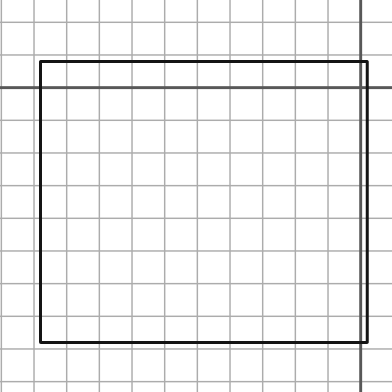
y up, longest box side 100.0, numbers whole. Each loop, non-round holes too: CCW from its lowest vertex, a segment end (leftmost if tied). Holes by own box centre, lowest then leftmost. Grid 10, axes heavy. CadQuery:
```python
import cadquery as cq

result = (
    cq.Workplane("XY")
    .moveTo(-98.0, -78.0)
    .lineTo(2.0, -78.0)
    .lineTo(2.0, 8.0)
    .lineTo(-98.0, 8.0)
    .close()
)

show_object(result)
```